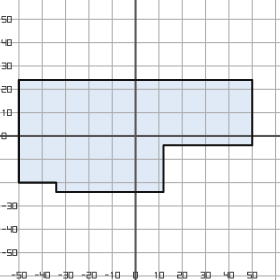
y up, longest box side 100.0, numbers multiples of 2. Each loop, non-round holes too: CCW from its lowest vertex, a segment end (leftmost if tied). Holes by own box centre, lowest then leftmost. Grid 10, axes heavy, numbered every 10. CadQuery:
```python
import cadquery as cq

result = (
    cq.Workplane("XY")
    .moveTo(-34.0, -24.0)
    .lineTo(12.0, -24.0)
    .lineTo(12.0, -4.0)
    .lineTo(50.0, -4.0)
    .lineTo(50.0, 24.0)
    .lineTo(-50.0, 24.0)
    .lineTo(-50.0, -20.0)
    .lineTo(-34.0, -20.0)
    .close()
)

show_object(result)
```